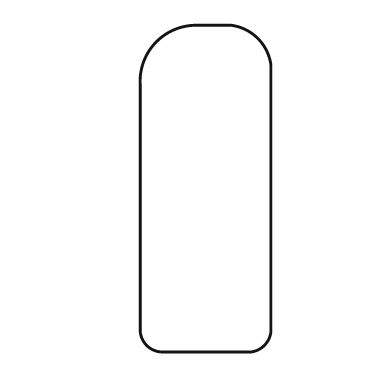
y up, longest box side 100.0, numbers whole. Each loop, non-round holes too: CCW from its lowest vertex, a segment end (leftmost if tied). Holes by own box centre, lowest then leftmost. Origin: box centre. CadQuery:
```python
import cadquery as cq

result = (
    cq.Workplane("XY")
    .moveTo(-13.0, -50.0)
    .lineTo(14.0, -50.0)
    .threePointArc((18.0, -48.0), (20.0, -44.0))
    .lineTo(20.0, 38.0)
    .threePointArc((16.0, 46.0), (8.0, 50.0))
    .lineTo(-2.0, 50.0)
    .threePointArc((-15.0, 45.0), (-20.0, 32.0))
    .lineTo(-20.0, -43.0)
    .threePointArc((-18.0, -48.0), (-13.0, -50.0))
    .close()
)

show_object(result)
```